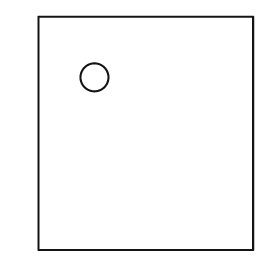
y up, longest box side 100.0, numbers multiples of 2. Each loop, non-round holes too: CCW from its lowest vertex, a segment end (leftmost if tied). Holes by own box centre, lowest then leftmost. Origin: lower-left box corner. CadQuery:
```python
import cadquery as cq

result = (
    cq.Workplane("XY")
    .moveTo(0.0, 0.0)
    .lineTo(92.0, 0.0)
    .lineTo(92.0, 100.0)
    .lineTo(0.0, 100.0)
    .close()
    .moveTo(24.0, 74.0)
    .circle(6.0)
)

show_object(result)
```